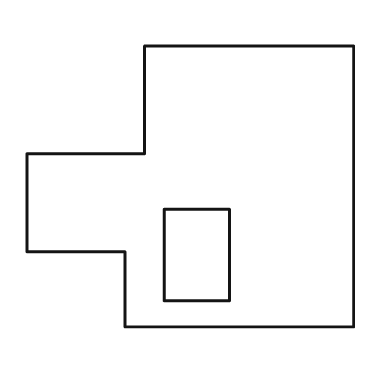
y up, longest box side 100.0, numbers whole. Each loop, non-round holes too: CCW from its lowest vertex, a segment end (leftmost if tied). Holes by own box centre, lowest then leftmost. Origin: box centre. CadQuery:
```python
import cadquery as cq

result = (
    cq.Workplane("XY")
    .moveTo(-20.0, -43.0)
    .lineTo(50.0, -43.0)
    .lineTo(50.0, 43.0)
    .lineTo(-14.0, 43.0)
    .lineTo(-14.0, 10.0)
    .lineTo(-50.0, 10.0)
    .lineTo(-50.0, -20.0)
    .lineTo(-20.0, -20.0)
    .close()
    .moveTo(-8.0, -35.0)
    .lineTo(12.0, -35.0)
    .lineTo(12.0, -7.0)
    .lineTo(-8.0, -7.0)
    .close()
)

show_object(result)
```